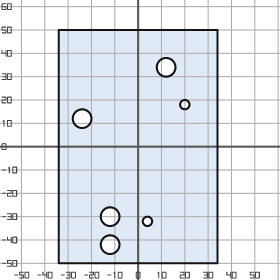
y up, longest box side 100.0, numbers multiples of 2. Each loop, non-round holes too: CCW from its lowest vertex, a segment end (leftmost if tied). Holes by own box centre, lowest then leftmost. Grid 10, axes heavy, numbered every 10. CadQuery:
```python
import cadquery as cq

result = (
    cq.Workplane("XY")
    .moveTo(-34.0, -50.0)
    .lineTo(34.0, -50.0)
    .lineTo(34.0, 50.0)
    .lineTo(-34.0, 50.0)
    .close()
    .moveTo(-12.0, -42.0)
    .circle(4.0)
    .moveTo(4.0, -32.0)
    .circle(2.0)
    .moveTo(-12.0, -30.0)
    .circle(4.0)
    .moveTo(-24.0, 12.0)
    .circle(4.0)
    .moveTo(20.0, 18.0)
    .circle(2.0)
    .moveTo(12.0, 34.0)
    .circle(4.0)
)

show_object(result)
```